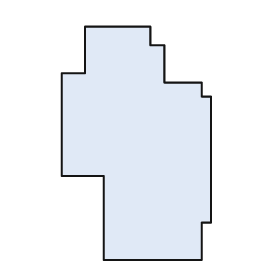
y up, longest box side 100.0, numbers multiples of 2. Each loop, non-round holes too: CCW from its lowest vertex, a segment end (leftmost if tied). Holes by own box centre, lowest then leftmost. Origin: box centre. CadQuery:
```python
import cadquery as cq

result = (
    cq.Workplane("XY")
    .moveTo(-14.0, -50.0)
    .lineTo(28.0, -50.0)
    .lineTo(28.0, -34.0)
    .lineTo(32.0, -34.0)
    .lineTo(32.0, 20.0)
    .lineTo(28.0, 20.0)
    .lineTo(28.0, 26.0)
    .lineTo(12.0, 26.0)
    .lineTo(12.0, 42.0)
    .lineTo(6.0, 42.0)
    .lineTo(6.0, 50.0)
    .lineTo(-22.0, 50.0)
    .lineTo(-22.0, 30.0)
    .lineTo(-32.0, 30.0)
    .lineTo(-32.0, -14.0)
    .lineTo(-14.0, -14.0)
    .close()
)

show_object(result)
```